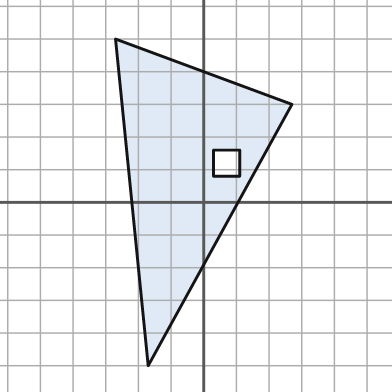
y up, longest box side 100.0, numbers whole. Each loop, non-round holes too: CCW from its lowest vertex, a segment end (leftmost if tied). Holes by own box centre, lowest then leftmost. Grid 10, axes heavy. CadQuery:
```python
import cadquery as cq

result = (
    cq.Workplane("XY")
    .moveTo(-17.0, -50.0)
    .lineTo(27.0, 30.0)
    .lineTo(-27.0, 50.0)
    .close()
    .moveTo(3.0, 8.0)
    .lineTo(11.0, 8.0)
    .lineTo(11.0, 16.0)
    .lineTo(3.0, 16.0)
    .close()
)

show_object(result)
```